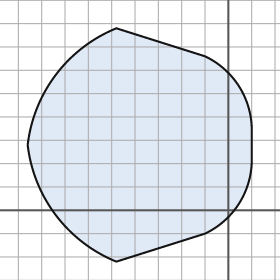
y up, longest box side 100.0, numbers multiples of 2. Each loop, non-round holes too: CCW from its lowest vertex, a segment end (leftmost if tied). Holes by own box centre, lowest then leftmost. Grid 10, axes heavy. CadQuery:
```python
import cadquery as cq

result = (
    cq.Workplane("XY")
    .moveTo(-48.0, -22.0)
    .lineTo(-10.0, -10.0)
    .threePointArc((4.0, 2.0), (10.0, 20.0))
    .lineTo(10.0, 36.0)
    .threePointArc((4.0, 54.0), (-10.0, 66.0))
    .lineTo(-48.0, 78.0)
    .threePointArc((-74.0, 58.0), (-86.0, 28.0))
    .threePointArc((-74.0, -2.0), (-48.0, -22.0))
    .close()
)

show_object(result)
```